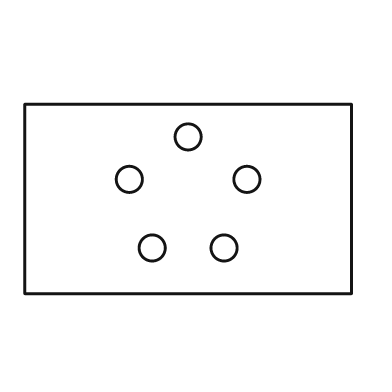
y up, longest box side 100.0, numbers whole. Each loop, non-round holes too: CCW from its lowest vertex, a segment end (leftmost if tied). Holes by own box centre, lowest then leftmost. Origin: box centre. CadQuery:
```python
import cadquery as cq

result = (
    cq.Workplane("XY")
    .moveTo(-50.0, -29.0)
    .lineTo(50.0, -29.0)
    .lineTo(50.0, 29.0)
    .lineTo(-50.0, 29.0)
    .close()
    .moveTo(-11.0, -15.0)
    .circle(4.0)
    .moveTo(11.0, -15.0)
    .circle(4.0)
    .moveTo(-18.0, 6.0)
    .circle(4.0)
    .moveTo(18.0, 6.0)
    .circle(4.0)
    .moveTo(0.0, 19.0)
    .circle(4.0)
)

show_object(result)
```